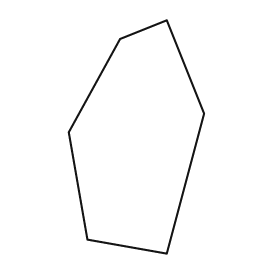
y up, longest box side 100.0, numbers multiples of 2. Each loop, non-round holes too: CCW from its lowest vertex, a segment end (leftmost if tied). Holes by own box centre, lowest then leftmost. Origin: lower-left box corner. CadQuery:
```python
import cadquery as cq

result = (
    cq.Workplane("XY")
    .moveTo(42.0, 0.0)
    .lineTo(58.0, 60.0)
    .lineTo(42.0, 100.0)
    .lineTo(22.0, 92.0)
    .lineTo(0.0, 52.0)
    .lineTo(8.0, 6.0)
    .close()
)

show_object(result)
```